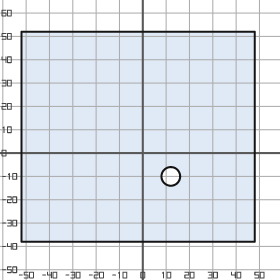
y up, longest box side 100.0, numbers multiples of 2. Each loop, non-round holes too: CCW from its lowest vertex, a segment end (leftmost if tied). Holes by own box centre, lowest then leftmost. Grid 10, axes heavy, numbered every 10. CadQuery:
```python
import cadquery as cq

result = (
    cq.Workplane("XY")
    .moveTo(-52.0, -38.0)
    .lineTo(48.0, -38.0)
    .lineTo(48.0, 52.0)
    .lineTo(-52.0, 52.0)
    .close()
    .moveTo(12.0, -10.0)
    .circle(4.0)
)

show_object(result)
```